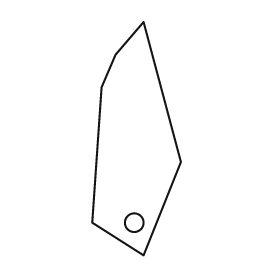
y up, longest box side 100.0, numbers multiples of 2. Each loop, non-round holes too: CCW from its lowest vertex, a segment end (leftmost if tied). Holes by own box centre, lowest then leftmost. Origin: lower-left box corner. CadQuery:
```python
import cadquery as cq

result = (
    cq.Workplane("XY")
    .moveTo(22.0, 0.0)
    .lineTo(38.0, 40.0)
    .lineTo(22.0, 100.0)
    .lineTo(10.0, 86.0)
    .lineTo(4.0, 72.0)
    .lineTo(0.0, 14.0)
    .close()
    .moveTo(18.0, 14.0)
    .circle(4.0)
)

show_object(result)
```